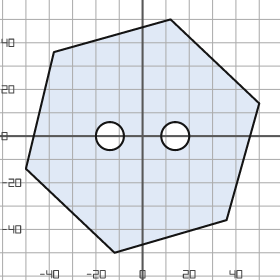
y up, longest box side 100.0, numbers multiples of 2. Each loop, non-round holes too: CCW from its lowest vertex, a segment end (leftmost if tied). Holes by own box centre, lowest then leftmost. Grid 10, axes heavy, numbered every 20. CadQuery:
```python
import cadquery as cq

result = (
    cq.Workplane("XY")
    .moveTo(-12.0, -50.0)
    .lineTo(36.0, -36.0)
    .lineTo(50.0, 14.0)
    .lineTo(12.0, 50.0)
    .lineTo(-38.0, 36.0)
    .lineTo(-50.0, -14.0)
    .close()
    .moveTo(-14.0, 0.0)
    .circle(6.0)
    .moveTo(14.0, 0.0)
    .circle(6.0)
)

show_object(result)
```